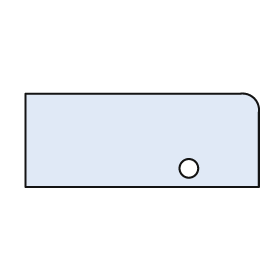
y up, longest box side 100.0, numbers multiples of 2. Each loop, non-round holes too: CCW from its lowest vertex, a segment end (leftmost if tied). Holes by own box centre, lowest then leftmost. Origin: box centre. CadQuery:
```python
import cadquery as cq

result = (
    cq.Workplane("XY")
    .moveTo(-50.0, -20.0)
    .lineTo(50.0, -20.0)
    .lineTo(50.0, 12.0)
    .threePointArc((48.0, 18.0), (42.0, 20.0))
    .lineTo(-50.0, 20.0)
    .close()
    .moveTo(20.0, -12.0)
    .circle(4.0)
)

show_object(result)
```